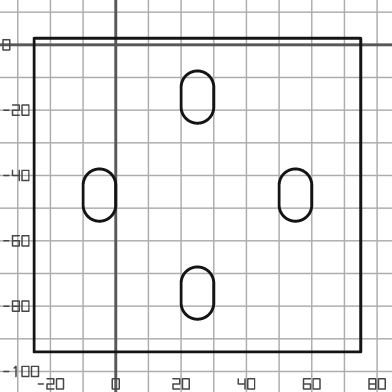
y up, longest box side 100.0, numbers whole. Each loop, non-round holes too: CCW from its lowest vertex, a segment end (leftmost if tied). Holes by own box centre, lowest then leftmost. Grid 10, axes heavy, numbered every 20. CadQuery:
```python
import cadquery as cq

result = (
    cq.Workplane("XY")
    .moveTo(-25.0, -94.0)
    .lineTo(75.0, -94.0)
    .lineTo(75.0, 2.0)
    .lineTo(-25.0, 2.0)
    .close()
    .moveTo(20.0, -79.0)
    .threePointArc((25.0, -84.0), (30.0, -79.0))
    .lineTo(30.0, -73.0)
    .threePointArc((25.0, -68.0), (20.0, -73.0))
    .close()
    .moveTo(-10.0, -49.0)
    .threePointArc((-5.0, -54.0), (0.0, -49.0))
    .lineTo(0.0, -43.0)
    .threePointArc((-5.0, -38.0), (-10.0, -43.0))
    .close()
    .moveTo(50.0, -49.0)
    .threePointArc((55.0, -54.0), (60.0, -49.0))
    .lineTo(60.0, -43.0)
    .threePointArc((55.0, -38.0), (50.0, -43.0))
    .close()
    .moveTo(20.0, -19.0)
    .threePointArc((25.0, -24.0), (30.0, -19.0))
    .lineTo(30.0, -13.0)
    .threePointArc((25.0, -8.0), (20.0, -13.0))
    .close()
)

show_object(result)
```